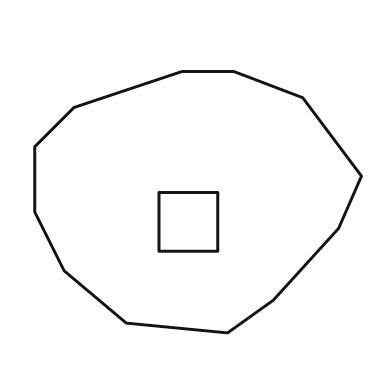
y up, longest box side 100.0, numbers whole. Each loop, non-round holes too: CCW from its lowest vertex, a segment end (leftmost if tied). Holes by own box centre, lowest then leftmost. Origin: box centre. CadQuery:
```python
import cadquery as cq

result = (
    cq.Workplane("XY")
    .moveTo(9.0, -40.0)
    .lineTo(23.0, -30.0)
    .lineTo(43.0, -8.0)
    .lineTo(50.0, 8.0)
    .lineTo(32.0, 32.0)
    .lineTo(11.0, 40.0)
    .lineTo(-5.0, 40.0)
    .lineTo(-38.0, 29.0)
    .lineTo(-50.0, 17.0)
    .lineTo(-50.0, -3.0)
    .lineTo(-41.0, -21.0)
    .lineTo(-22.0, -37.0)
    .close()
    .moveTo(-12.0, -15.0)
    .lineTo(6.0, -15.0)
    .lineTo(6.0, 3.0)
    .lineTo(-12.0, 3.0)
    .close()
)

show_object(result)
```